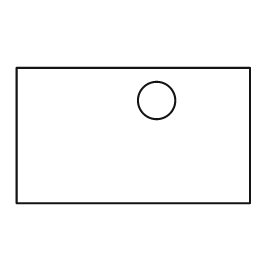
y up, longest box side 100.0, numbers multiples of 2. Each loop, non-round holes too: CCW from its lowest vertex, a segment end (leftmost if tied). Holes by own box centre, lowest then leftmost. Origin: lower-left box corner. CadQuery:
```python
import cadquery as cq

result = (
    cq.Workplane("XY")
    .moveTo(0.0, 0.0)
    .lineTo(100.0, 0.0)
    .lineTo(100.0, 58.0)
    .lineTo(0.0, 58.0)
    .close()
    .moveTo(60.0, 44.0)
    .circle(8.0)
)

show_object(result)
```